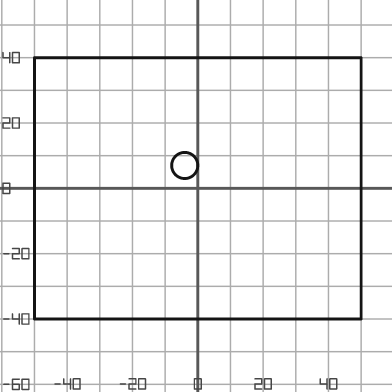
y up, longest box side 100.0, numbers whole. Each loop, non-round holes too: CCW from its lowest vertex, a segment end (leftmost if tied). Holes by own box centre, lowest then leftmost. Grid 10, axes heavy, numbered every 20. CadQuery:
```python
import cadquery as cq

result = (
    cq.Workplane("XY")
    .moveTo(-50.0, -40.0)
    .lineTo(50.0, -40.0)
    .lineTo(50.0, 40.0)
    .lineTo(-50.0, 40.0)
    .close()
    .moveTo(-4.0, 7.0)
    .circle(4.0)
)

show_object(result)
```